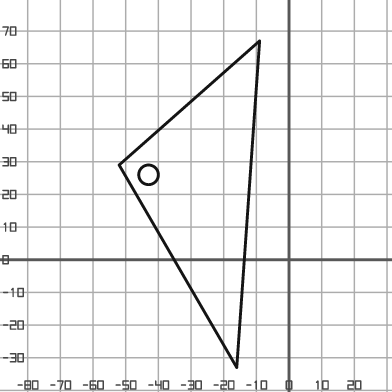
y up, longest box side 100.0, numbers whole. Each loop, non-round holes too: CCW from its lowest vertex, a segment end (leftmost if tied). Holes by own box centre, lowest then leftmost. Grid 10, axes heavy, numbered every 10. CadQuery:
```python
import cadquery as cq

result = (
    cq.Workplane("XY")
    .moveTo(-16.0, -33.0)
    .lineTo(-9.0, 67.0)
    .lineTo(-52.0, 29.0)
    .close()
    .moveTo(-43.0, 26.0)
    .circle(3.0)
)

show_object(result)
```